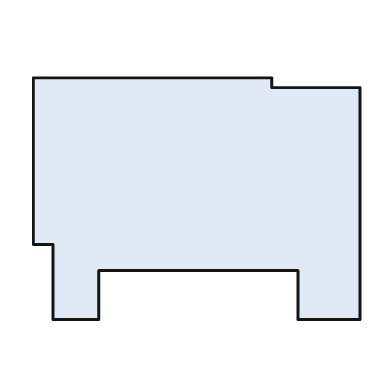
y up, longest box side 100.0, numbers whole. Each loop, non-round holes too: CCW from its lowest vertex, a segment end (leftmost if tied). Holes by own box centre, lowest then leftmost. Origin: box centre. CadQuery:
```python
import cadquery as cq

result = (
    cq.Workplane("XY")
    .moveTo(-44.0, -37.0)
    .lineTo(-30.0, -37.0)
    .lineTo(-30.0, -22.0)
    .lineTo(31.0, -22.0)
    .lineTo(31.0, -37.0)
    .lineTo(50.0, -37.0)
    .lineTo(50.0, 34.0)
    .lineTo(23.0, 34.0)
    .lineTo(23.0, 37.0)
    .lineTo(-50.0, 37.0)
    .lineTo(-50.0, -14.0)
    .lineTo(-44.0, -14.0)
    .close()
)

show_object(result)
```